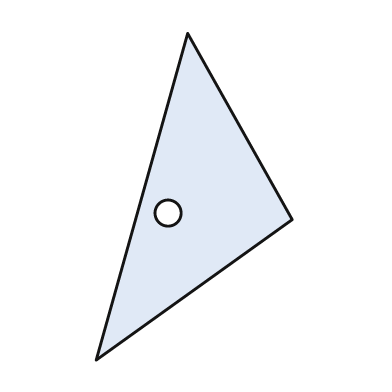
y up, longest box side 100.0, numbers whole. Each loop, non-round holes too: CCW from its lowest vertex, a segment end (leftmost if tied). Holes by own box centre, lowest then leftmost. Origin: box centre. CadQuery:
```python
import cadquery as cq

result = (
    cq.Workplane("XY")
    .moveTo(-30.0, -50.0)
    .lineTo(30.0, -7.0)
    .lineTo(-2.0, 50.0)
    .close()
    .moveTo(-8.0, -5.0)
    .circle(4.0)
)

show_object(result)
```